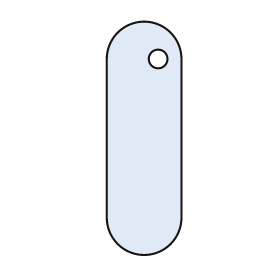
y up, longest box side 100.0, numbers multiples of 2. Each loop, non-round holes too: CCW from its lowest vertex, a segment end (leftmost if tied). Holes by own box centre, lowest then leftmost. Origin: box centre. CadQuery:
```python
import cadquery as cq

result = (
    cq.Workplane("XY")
    .moveTo(-16.0, -34.0)
    .threePointArc((0.0, -50.0), (16.0, -34.0))
    .lineTo(16.0, 34.0)
    .threePointArc((0.0, 50.0), (-16.0, 34.0))
    .close()
    .moveTo(6.0, 34.0)
    .circle(4.0)
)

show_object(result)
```